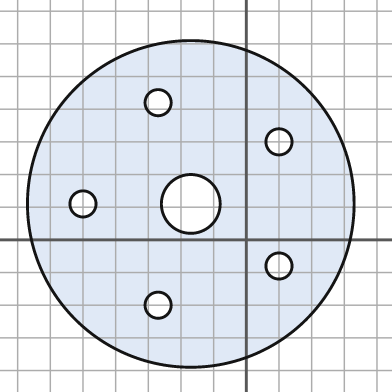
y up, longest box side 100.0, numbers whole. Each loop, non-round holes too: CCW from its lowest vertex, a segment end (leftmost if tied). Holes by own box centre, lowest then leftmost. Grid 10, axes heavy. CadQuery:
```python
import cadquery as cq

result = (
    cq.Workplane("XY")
    .moveTo(-17.0, 11.0)
    .circle(50.0)
    .moveTo(-27.0, -20.0)
    .circle(4.0)
    .moveTo(10.0, -8.0)
    .circle(4.0)
    .moveTo(-50.0, 11.0)
    .circle(4.0)
    .moveTo(-17.0, 11.0)
    .circle(9.0)
    .moveTo(10.0, 30.0)
    .circle(4.0)
    .moveTo(-27.0, 42.0)
    .circle(4.0)
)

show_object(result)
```